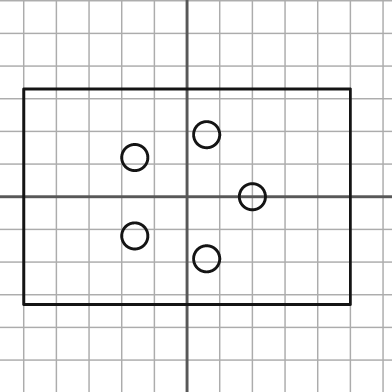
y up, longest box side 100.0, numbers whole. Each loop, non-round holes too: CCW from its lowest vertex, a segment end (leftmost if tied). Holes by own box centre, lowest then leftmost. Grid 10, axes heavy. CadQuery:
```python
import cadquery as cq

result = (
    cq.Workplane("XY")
    .moveTo(-50.0, -33.0)
    .lineTo(50.0, -33.0)
    .lineTo(50.0, 33.0)
    .lineTo(-50.0, 33.0)
    .close()
    .moveTo(6.0, -19.0)
    .circle(4.0)
    .moveTo(-16.0, -12.0)
    .circle(4.0)
    .moveTo(20.0, 0.0)
    .circle(4.0)
    .moveTo(-16.0, 12.0)
    .circle(4.0)
    .moveTo(6.0, 19.0)
    .circle(4.0)
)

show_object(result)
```